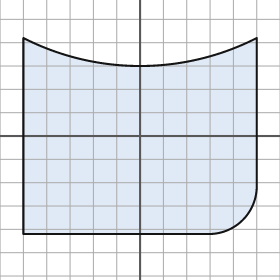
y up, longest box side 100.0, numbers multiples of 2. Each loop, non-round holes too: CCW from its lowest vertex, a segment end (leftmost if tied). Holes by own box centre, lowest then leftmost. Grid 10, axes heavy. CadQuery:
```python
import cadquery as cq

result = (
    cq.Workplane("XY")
    .moveTo(-50.0, -42.0)
    .lineTo(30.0, -42.0)
    .threePointArc((44.0, -36.0), (50.0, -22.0))
    .lineTo(50.0, 42.0)
    .threePointArc((0.0, 30.0), (-50.0, 42.0))
    .close()
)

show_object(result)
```